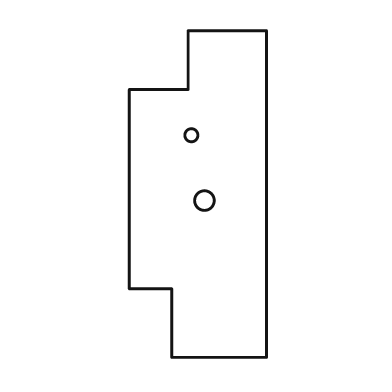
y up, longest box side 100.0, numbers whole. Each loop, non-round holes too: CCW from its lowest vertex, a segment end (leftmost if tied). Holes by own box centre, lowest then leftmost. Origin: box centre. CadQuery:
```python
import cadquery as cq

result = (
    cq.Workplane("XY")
    .moveTo(-8.0, -50.0)
    .lineTo(21.0, -50.0)
    .lineTo(21.0, 50.0)
    .lineTo(-3.0, 50.0)
    .lineTo(-3.0, 32.0)
    .lineTo(-21.0, 32.0)
    .lineTo(-21.0, -29.0)
    .lineTo(-8.0, -29.0)
    .close()
    .moveTo(2.0, -2.0)
    .circle(3.0)
    .moveTo(-2.0, 18.0)
    .circle(2.0)
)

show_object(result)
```